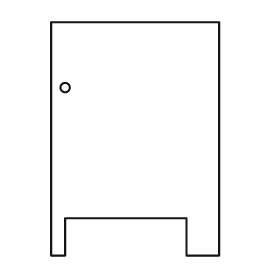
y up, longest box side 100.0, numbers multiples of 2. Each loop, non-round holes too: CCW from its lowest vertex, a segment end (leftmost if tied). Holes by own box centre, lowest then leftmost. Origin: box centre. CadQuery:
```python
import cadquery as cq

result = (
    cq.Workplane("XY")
    .moveTo(-36.0, -50.0)
    .lineTo(-30.0, -50.0)
    .lineTo(-30.0, -34.0)
    .lineTo(22.0, -34.0)
    .lineTo(22.0, -50.0)
    .lineTo(36.0, -50.0)
    .lineTo(36.0, 50.0)
    .lineTo(-36.0, 50.0)
    .close()
    .moveTo(-30.0, 22.0)
    .circle(2.0)
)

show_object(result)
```